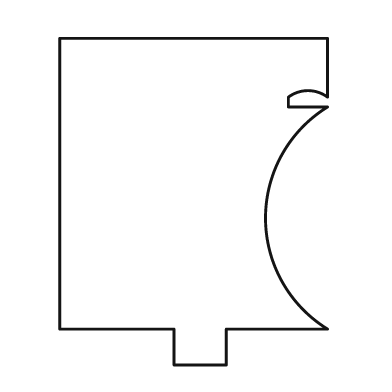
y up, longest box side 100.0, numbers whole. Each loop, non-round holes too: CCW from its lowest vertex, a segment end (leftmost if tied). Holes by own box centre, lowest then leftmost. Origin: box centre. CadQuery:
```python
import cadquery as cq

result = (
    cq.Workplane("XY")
    .moveTo(-6.0, -50.0)
    .lineTo(10.0, -50.0)
    .lineTo(10.0, -39.0)
    .lineTo(41.0, -39.0)
    .threePointArc((22.0, -5.0), (41.0, 29.0))
    .lineTo(29.0, 29.0)
    .lineTo(29.0, 32.0)
    .threePointArc((35.0, 34.0), (41.0, 32.0))
    .lineTo(41.0, 50.0)
    .lineTo(-41.0, 50.0)
    .lineTo(-41.0, -39.0)
    .lineTo(-6.0, -39.0)
    .close()
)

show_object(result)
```